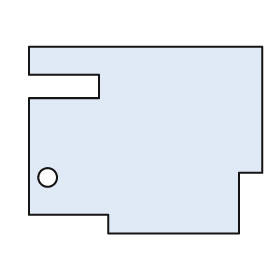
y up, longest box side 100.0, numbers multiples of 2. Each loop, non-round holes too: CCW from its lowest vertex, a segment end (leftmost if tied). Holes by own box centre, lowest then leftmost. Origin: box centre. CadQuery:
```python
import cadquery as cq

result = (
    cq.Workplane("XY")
    .moveTo(-16.0, -40.0)
    .lineTo(40.0, -40.0)
    .lineTo(40.0, -14.0)
    .lineTo(50.0, -14.0)
    .lineTo(50.0, 40.0)
    .lineTo(-50.0, 40.0)
    .lineTo(-50.0, 28.0)
    .lineTo(-20.0, 28.0)
    .lineTo(-20.0, 18.0)
    .lineTo(-50.0, 18.0)
    .lineTo(-50.0, -32.0)
    .lineTo(-16.0, -32.0)
    .close()
    .moveTo(-42.0, -16.0)
    .circle(4.0)
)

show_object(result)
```